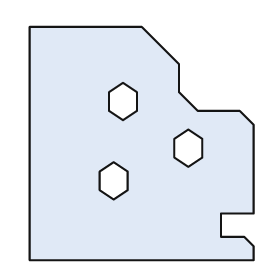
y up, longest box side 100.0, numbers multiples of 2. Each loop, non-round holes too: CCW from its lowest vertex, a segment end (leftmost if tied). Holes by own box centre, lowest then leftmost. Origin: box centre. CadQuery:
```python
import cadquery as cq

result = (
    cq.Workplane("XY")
    .moveTo(-48.0, -50.0)
    .lineTo(48.0, -50.0)
    .lineTo(48.0, -44.0)
    .lineTo(44.0, -40.0)
    .lineTo(34.0, -40.0)
    .lineTo(34.0, -30.0)
    .lineTo(48.0, -30.0)
    .lineTo(48.0, 8.0)
    .lineTo(42.0, 14.0)
    .lineTo(24.0, 14.0)
    .lineTo(16.0, 22.0)
    .lineTo(16.0, 34.0)
    .lineTo(0.0, 50.0)
    .lineTo(-48.0, 50.0)
    .close()
    .moveTo(-12.0, -24.0)
    .lineTo(-6.0, -20.0)
    .lineTo(-6.0, -12.0)
    .lineTo(-12.0, -8.0)
    .lineTo(-18.0, -12.0)
    .lineTo(-18.0, -20.0)
    .close()
    .moveTo(20.0, -10.0)
    .lineTo(26.0, -6.0)
    .lineTo(26.0, 2.0)
    .lineTo(20.0, 6.0)
    .lineTo(14.0, 2.0)
    .lineTo(14.0, -6.0)
    .close()
    .moveTo(-8.0, 10.0)
    .lineTo(-2.0, 14.0)
    .lineTo(-2.0, 22.0)
    .lineTo(-8.0, 26.0)
    .lineTo(-14.0, 22.0)
    .lineTo(-14.0, 14.0)
    .close()
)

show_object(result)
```